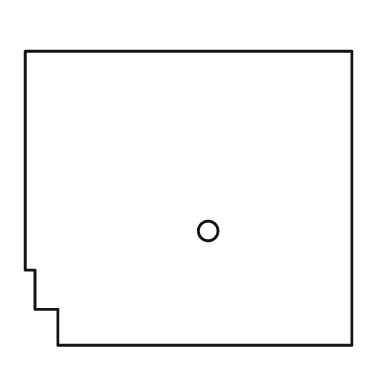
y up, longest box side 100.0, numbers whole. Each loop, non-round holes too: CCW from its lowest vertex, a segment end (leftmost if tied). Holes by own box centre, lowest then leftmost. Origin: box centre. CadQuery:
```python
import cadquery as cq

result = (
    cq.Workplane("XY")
    .moveTo(-40.0, -45.0)
    .lineTo(50.0, -45.0)
    .lineTo(50.0, 45.0)
    .lineTo(-50.0, 45.0)
    .lineTo(-50.0, -22.0)
    .lineTo(-47.0, -22.0)
    .lineTo(-47.0, -34.0)
    .lineTo(-40.0, -34.0)
    .close()
    .moveTo(6.0, -10.0)
    .circle(3.0)
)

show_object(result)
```